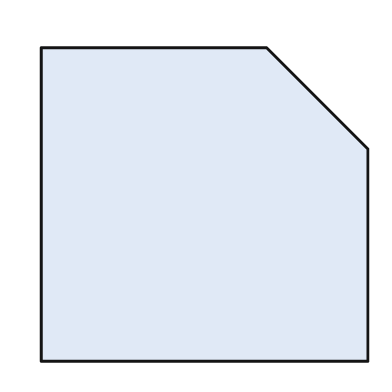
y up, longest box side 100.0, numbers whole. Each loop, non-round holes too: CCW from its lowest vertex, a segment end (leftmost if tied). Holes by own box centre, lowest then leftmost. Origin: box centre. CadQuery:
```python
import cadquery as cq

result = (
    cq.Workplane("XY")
    .moveTo(-50.0, -48.0)
    .lineTo(50.0, -48.0)
    .lineTo(50.0, 17.0)
    .lineTo(19.0, 48.0)
    .lineTo(-50.0, 48.0)
    .close()
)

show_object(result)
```